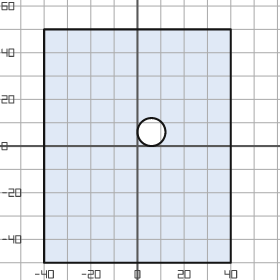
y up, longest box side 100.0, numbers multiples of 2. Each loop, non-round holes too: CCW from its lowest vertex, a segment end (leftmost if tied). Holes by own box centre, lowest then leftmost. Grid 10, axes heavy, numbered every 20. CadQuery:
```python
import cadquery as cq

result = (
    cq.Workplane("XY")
    .moveTo(-40.0, -50.0)
    .lineTo(40.0, -50.0)
    .lineTo(40.0, 50.0)
    .lineTo(-40.0, 50.0)
    .close()
    .moveTo(6.0, 6.0)
    .circle(6.0)
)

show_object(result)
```